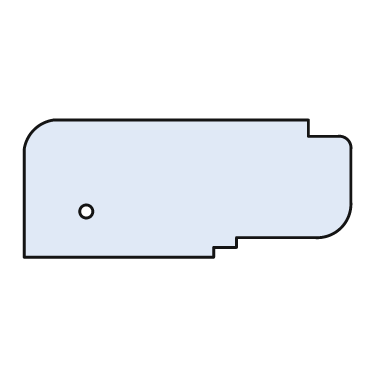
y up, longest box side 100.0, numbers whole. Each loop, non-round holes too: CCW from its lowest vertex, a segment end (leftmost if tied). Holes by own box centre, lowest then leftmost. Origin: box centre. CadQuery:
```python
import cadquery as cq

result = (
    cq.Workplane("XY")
    .moveTo(-50.0, -21.0)
    .lineTo(8.0, -21.0)
    .lineTo(8.0, -18.0)
    .lineTo(15.0, -18.0)
    .lineTo(15.0, -15.0)
    .lineTo(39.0, -15.0)
    .threePointArc((47.0, -12.0), (50.0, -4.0))
    .lineTo(50.0, 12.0)
    .threePointArc((49.0, 15.0), (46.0, 16.0))
    .lineTo(37.0, 16.0)
    .lineTo(37.0, 21.0)
    .lineTo(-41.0, 21.0)
    .threePointArc((-47.0, 18.0), (-50.0, 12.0))
    .close()
    .moveTo(-31.0, -7.0)
    .circle(2.0)
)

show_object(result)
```